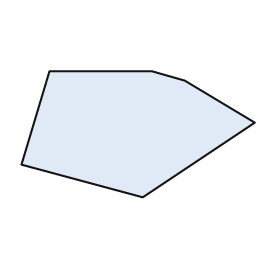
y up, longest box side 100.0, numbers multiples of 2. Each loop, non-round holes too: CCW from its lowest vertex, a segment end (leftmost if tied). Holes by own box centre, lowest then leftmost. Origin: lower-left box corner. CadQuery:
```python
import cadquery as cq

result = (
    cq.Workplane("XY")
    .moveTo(52.0, 0.0)
    .lineTo(100.0, 32.0)
    .lineTo(70.0, 50.0)
    .lineTo(56.0, 54.0)
    .lineTo(12.0, 54.0)
    .lineTo(0.0, 14.0)
    .close()
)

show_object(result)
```